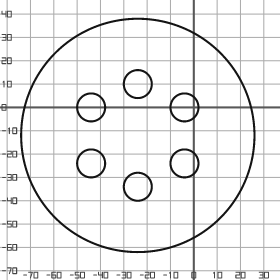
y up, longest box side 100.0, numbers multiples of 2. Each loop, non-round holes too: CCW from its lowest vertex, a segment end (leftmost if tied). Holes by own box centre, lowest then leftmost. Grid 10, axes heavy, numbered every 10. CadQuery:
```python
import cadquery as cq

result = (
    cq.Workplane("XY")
    .moveTo(-24.0, -12.0)
    .circle(50.0)
    .moveTo(-24.0, -34.0)
    .circle(6.0)
    .moveTo(-44.0, -24.0)
    .circle(6.0)
    .moveTo(-4.0, -24.0)
    .circle(6.0)
    .moveTo(-44.0, 0.0)
    .circle(6.0)
    .moveTo(-4.0, 0.0)
    .circle(6.0)
    .moveTo(-24.0, 10.0)
    .circle(6.0)
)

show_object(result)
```